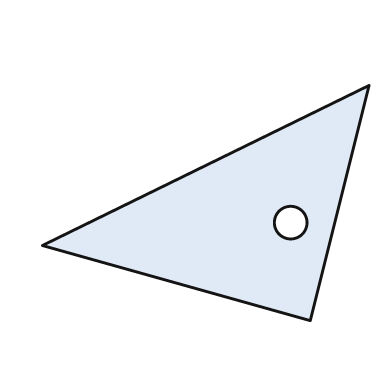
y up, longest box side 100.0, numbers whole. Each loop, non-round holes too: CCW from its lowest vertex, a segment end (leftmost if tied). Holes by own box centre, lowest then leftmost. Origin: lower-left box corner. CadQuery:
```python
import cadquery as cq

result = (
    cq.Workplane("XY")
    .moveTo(82.0, 0.0)
    .lineTo(100.0, 72.0)
    .lineTo(0.0, 23.0)
    .close()
    .moveTo(76.0, 30.0)
    .circle(5.0)
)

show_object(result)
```